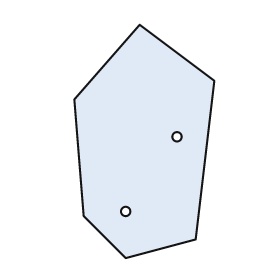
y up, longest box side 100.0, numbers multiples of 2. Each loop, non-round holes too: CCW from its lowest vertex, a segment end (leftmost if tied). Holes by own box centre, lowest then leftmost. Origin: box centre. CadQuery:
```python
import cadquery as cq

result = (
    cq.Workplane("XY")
    .moveTo(-8.0, -50.0)
    .lineTo(22.0, -42.0)
    .lineTo(30.0, 26.0)
    .lineTo(-2.0, 50.0)
    .lineTo(-30.0, 18.0)
    .lineTo(-26.0, -32.0)
    .close()
    .moveTo(-8.0, -30.0)
    .circle(2.0)
    .moveTo(14.0, 2.0)
    .circle(2.0)
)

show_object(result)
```